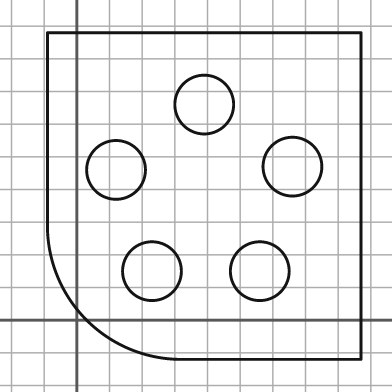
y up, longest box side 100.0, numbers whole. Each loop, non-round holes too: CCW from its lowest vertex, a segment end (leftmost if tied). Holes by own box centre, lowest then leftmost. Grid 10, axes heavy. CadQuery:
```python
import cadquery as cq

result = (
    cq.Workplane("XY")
    .moveTo(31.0, -12.0)
    .lineTo(87.0, -12.0)
    .lineTo(87.0, 88.0)
    .lineTo(-9.0, 88.0)
    .lineTo(-9.0, 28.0)
    .threePointArc((3.0, 0.0), (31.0, -12.0))
    .close()
    .moveTo(23.0, 15.0)
    .circle(9.0)
    .moveTo(56.0, 15.0)
    .circle(9.0)
    .moveTo(12.0, 46.0)
    .circle(9.0)
    .moveTo(66.0, 47.0)
    .circle(9.0)
    .moveTo(39.0, 66.0)
    .circle(9.0)
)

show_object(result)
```